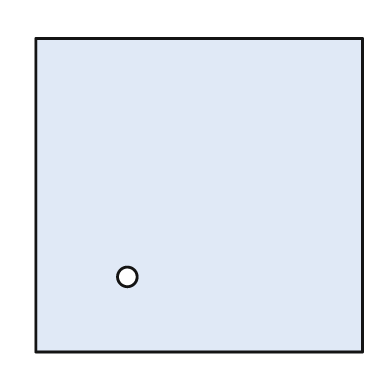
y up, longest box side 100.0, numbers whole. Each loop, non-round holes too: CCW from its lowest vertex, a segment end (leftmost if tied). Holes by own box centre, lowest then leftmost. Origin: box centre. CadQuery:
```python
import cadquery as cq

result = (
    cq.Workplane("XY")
    .moveTo(-50.0, -48.0)
    .lineTo(50.0, -48.0)
    .lineTo(50.0, 48.0)
    .lineTo(-50.0, 48.0)
    .close()
    .moveTo(-22.0, -25.0)
    .circle(3.0)
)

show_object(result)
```